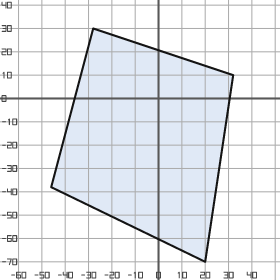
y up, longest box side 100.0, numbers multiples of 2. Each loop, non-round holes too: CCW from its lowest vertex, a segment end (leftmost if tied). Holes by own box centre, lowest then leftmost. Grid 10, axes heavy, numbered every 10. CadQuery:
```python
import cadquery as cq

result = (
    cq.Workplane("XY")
    .moveTo(20.0, -70.0)
    .lineTo(32.0, 10.0)
    .lineTo(-28.0, 30.0)
    .lineTo(-46.0, -38.0)
    .close()
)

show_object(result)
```